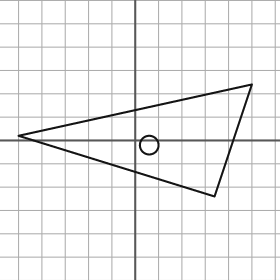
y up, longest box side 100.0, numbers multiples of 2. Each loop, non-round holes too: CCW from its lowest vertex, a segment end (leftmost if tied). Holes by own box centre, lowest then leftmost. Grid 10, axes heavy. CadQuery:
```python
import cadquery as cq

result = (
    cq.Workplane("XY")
    .moveTo(34.0, -24.0)
    .lineTo(50.0, 24.0)
    .lineTo(-50.0, 2.0)
    .close()
    .moveTo(6.0, -2.0)
    .circle(4.0)
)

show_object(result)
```